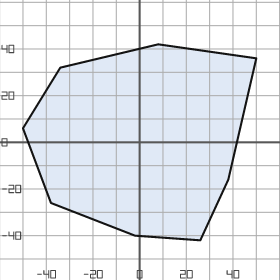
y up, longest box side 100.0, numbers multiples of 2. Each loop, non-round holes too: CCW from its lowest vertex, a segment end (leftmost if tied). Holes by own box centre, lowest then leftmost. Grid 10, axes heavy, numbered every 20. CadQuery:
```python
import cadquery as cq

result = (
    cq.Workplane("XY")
    .moveTo(26.0, -42.0)
    .lineTo(38.0, -16.0)
    .lineTo(50.0, 36.0)
    .lineTo(8.0, 42.0)
    .lineTo(-34.0, 32.0)
    .lineTo(-50.0, 6.0)
    .lineTo(-38.0, -26.0)
    .lineTo(-2.0, -40.0)
    .close()
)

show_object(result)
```